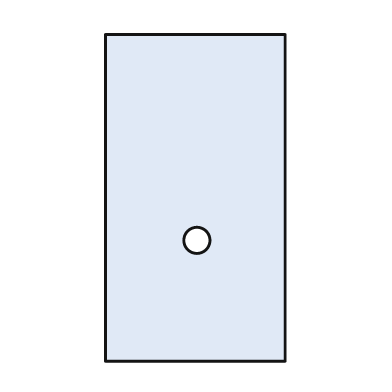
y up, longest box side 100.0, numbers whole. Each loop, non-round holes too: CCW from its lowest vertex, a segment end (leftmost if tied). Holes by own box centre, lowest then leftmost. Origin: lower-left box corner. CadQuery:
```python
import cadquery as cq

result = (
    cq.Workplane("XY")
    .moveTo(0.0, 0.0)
    .lineTo(55.0, 0.0)
    .lineTo(55.0, 100.0)
    .lineTo(0.0, 100.0)
    .close()
    .moveTo(28.0, 37.0)
    .circle(4.0)
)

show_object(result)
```